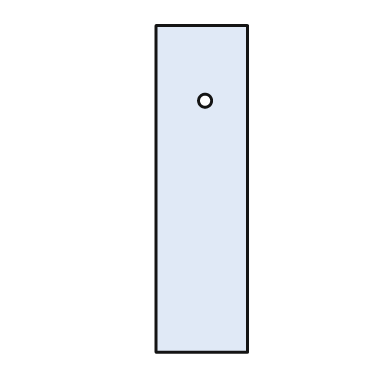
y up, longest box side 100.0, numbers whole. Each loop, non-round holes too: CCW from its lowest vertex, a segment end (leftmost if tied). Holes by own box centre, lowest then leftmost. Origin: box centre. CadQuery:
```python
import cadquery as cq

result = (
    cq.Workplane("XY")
    .moveTo(-14.0, -50.0)
    .lineTo(14.0, -50.0)
    .lineTo(14.0, 50.0)
    .lineTo(-14.0, 50.0)
    .close()
    .moveTo(1.0, 27.0)
    .circle(2.0)
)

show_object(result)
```